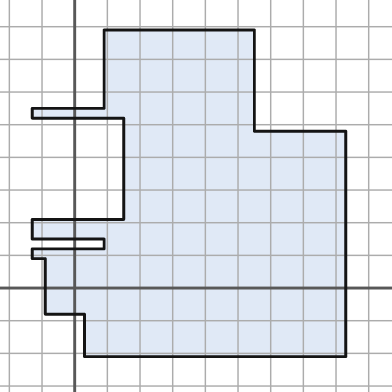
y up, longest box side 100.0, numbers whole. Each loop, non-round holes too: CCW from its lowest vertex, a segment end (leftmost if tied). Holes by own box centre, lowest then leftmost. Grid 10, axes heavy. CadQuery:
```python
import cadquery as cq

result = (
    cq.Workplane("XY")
    .moveTo(3.0, -21.0)
    .lineTo(83.0, -21.0)
    .lineTo(83.0, 48.0)
    .lineTo(55.0, 48.0)
    .lineTo(55.0, 79.0)
    .lineTo(9.0, 79.0)
    .lineTo(9.0, 55.0)
    .lineTo(-13.0, 55.0)
    .lineTo(-13.0, 52.0)
    .lineTo(15.0, 52.0)
    .lineTo(15.0, 21.0)
    .lineTo(-13.0, 21.0)
    .lineTo(-13.0, 15.0)
    .lineTo(9.0, 15.0)
    .lineTo(9.0, 12.0)
    .lineTo(-13.0, 12.0)
    .lineTo(-13.0, 9.0)
    .lineTo(-9.0, 9.0)
    .lineTo(-9.0, -8.0)
    .lineTo(3.0, -8.0)
    .close()
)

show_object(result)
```